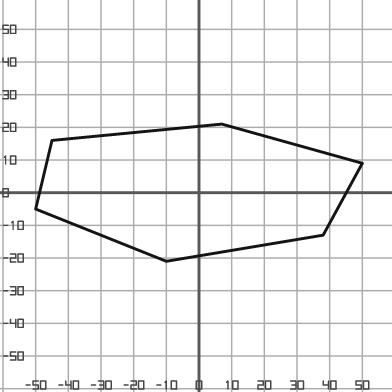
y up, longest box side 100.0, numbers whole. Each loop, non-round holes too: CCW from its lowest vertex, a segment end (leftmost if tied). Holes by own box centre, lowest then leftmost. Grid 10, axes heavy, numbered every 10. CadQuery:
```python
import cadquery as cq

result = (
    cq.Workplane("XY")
    .moveTo(-10.0, -21.0)
    .lineTo(38.0, -13.0)
    .lineTo(50.0, 9.0)
    .lineTo(7.0, 21.0)
    .lineTo(-45.0, 16.0)
    .lineTo(-50.0, -5.0)
    .close()
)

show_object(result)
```